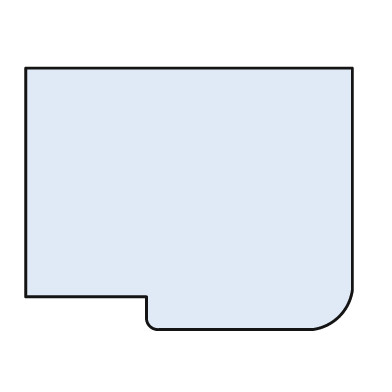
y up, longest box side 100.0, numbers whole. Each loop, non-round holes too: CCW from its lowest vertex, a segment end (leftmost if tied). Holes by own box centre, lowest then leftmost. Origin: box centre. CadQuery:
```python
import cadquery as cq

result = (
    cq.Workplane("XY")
    .moveTo(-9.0, -40.0)
    .lineTo(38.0, -40.0)
    .threePointArc((46.0, -36.0), (50.0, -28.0))
    .lineTo(50.0, 40.0)
    .lineTo(-50.0, 40.0)
    .lineTo(-50.0, -30.0)
    .lineTo(-13.0, -30.0)
    .lineTo(-13.0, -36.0)
    .threePointArc((-12.0, -39.0), (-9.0, -40.0))
    .close()
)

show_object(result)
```